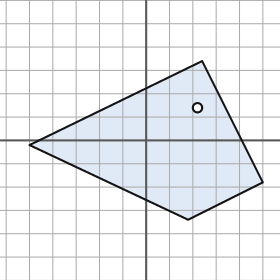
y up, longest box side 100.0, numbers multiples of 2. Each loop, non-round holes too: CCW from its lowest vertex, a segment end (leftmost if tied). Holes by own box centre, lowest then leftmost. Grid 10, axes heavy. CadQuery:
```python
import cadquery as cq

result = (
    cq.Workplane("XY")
    .moveTo(18.0, -34.0)
    .lineTo(50.0, -18.0)
    .lineTo(24.0, 34.0)
    .lineTo(-50.0, -2.0)
    .close()
    .moveTo(22.0, 14.0)
    .circle(2.0)
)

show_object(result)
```